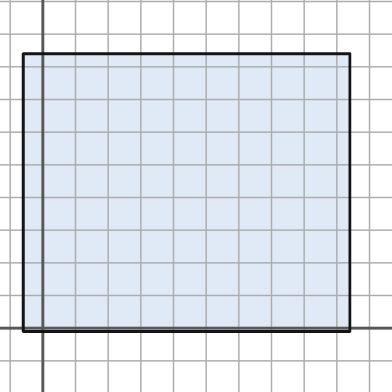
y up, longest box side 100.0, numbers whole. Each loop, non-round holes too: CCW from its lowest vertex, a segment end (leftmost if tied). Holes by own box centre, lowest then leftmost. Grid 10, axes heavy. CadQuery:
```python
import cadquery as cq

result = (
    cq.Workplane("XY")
    .moveTo(-6.0, -1.0)
    .lineTo(94.0, -1.0)
    .lineTo(94.0, 84.0)
    .lineTo(-6.0, 84.0)
    .close()
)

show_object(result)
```